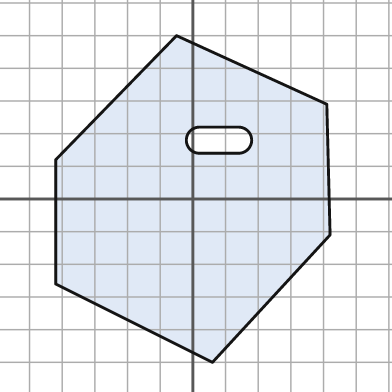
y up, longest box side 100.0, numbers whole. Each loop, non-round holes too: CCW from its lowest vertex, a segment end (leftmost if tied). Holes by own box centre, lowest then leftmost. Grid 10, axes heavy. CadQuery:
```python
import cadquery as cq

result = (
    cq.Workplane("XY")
    .moveTo(6.0, -50.0)
    .lineTo(42.0, -11.0)
    .lineTo(41.0, 29.0)
    .lineTo(-5.0, 50.0)
    .lineTo(-42.0, 12.0)
    .lineTo(-42.0, -26.0)
    .close()
    .moveTo(2.0, 14.0)
    .lineTo(14.0, 14.0)
    .threePointArc((18.0, 18.0), (14.0, 22.0))
    .lineTo(2.0, 22.0)
    .threePointArc((-2.0, 18.0), (2.0, 14.0))
    .close()
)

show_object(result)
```